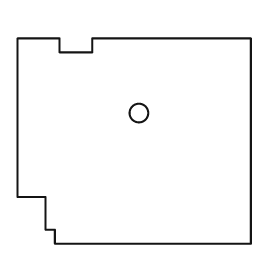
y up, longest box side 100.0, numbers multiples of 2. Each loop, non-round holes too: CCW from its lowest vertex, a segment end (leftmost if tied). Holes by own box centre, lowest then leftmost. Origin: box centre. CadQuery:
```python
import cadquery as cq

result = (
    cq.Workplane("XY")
    .moveTo(-34.0, -44.0)
    .lineTo(50.0, -44.0)
    .lineTo(50.0, 44.0)
    .lineTo(-18.0, 44.0)
    .lineTo(-18.0, 38.0)
    .lineTo(-32.0, 38.0)
    .lineTo(-32.0, 44.0)
    .lineTo(-50.0, 44.0)
    .lineTo(-50.0, -24.0)
    .lineTo(-38.0, -24.0)
    .lineTo(-38.0, -38.0)
    .lineTo(-34.0, -38.0)
    .close()
    .moveTo(2.0, 12.0)
    .circle(4.0)
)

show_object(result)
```